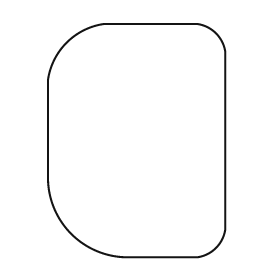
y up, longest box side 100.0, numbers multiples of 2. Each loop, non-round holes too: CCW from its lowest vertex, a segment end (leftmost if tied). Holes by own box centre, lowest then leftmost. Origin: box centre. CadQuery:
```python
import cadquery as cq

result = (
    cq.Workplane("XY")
    .moveTo(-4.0, -50.0)
    .lineTo(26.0, -50.0)
    .threePointArc((34.0, -46.0), (38.0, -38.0))
    .lineTo(38.0, 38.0)
    .threePointArc((34.0, 46.0), (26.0, 50.0))
    .lineTo(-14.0, 50.0)
    .threePointArc((-30.0, 42.0), (-38.0, 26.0))
    .lineTo(-38.0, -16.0)
    .threePointArc((-28.0, -40.0), (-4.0, -50.0))
    .close()
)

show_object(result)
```